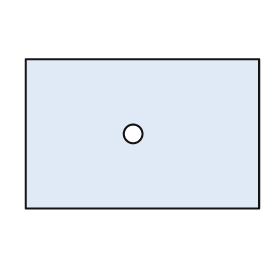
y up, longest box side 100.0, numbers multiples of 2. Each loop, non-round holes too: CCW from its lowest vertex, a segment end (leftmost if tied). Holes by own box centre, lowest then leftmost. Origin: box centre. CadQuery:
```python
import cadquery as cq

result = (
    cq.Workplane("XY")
    .moveTo(-50.0, -32.0)
    .lineTo(50.0, -32.0)
    .lineTo(50.0, 32.0)
    .lineTo(-50.0, 32.0)
    .close()
    .moveTo(-4.0, 0.0)
    .circle(4.0)
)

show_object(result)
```